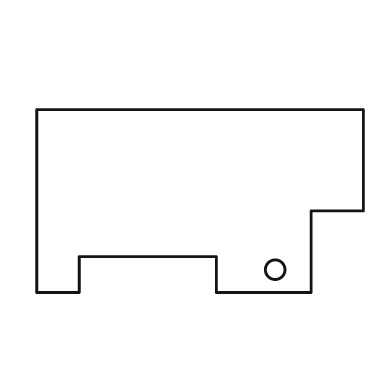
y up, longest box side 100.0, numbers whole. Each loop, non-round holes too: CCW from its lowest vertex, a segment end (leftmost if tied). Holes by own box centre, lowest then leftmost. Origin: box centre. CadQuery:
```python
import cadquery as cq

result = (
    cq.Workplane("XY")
    .moveTo(-50.0, -28.0)
    .lineTo(-37.0, -28.0)
    .lineTo(-37.0, -17.0)
    .lineTo(5.0, -17.0)
    .lineTo(5.0, -28.0)
    .lineTo(34.0, -28.0)
    .lineTo(34.0, -3.0)
    .lineTo(50.0, -3.0)
    .lineTo(50.0, 28.0)
    .lineTo(-50.0, 28.0)
    .close()
    .moveTo(23.0, -21.0)
    .circle(3.0)
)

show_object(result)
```